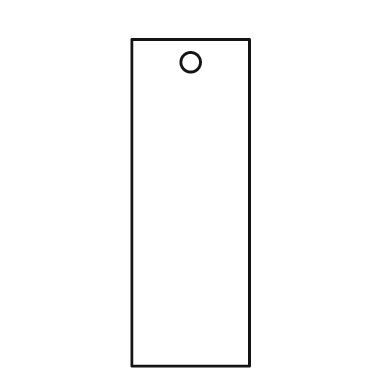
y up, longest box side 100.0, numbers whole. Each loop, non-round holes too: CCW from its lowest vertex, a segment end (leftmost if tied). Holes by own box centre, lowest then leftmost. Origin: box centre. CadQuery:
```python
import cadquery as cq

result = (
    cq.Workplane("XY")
    .moveTo(-18.0, -50.0)
    .lineTo(18.0, -50.0)
    .lineTo(18.0, 50.0)
    .lineTo(-18.0, 50.0)
    .close()
    .moveTo(0.0, 43.0)
    .circle(3.0)
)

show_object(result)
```